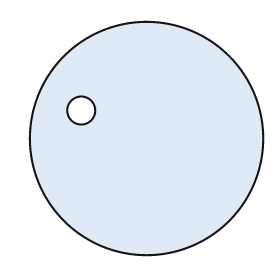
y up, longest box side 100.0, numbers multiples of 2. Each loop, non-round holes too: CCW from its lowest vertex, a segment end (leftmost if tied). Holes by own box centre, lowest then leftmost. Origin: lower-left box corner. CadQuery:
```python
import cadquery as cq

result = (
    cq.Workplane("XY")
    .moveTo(50.0, 50.0)
    .circle(50.0)
    .moveTo(22.0, 62.0)
    .circle(6.0)
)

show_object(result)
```